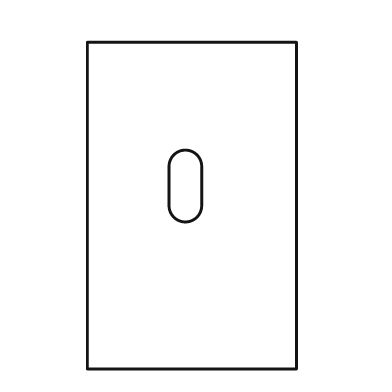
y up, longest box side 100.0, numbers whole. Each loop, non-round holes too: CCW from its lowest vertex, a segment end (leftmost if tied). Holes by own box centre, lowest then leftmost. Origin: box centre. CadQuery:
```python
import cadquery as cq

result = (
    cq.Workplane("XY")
    .moveTo(-32.0, -50.0)
    .lineTo(32.0, -50.0)
    .lineTo(32.0, 50.0)
    .lineTo(-32.0, 50.0)
    .close()
    .moveTo(-7.0, 0.0)
    .threePointArc((-2.0, -5.0), (3.0, 0.0))
    .lineTo(3.0, 12.0)
    .threePointArc((-2.0, 17.0), (-7.0, 12.0))
    .close()
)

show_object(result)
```